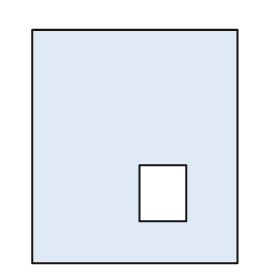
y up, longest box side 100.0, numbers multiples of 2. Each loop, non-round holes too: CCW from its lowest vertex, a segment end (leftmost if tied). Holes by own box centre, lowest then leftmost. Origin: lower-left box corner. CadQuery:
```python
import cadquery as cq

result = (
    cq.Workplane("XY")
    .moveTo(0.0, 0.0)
    .lineTo(88.0, 0.0)
    .lineTo(88.0, 100.0)
    .lineTo(0.0, 100.0)
    .close()
    .moveTo(46.0, 18.0)
    .lineTo(66.0, 18.0)
    .lineTo(66.0, 42.0)
    .lineTo(46.0, 42.0)
    .close()
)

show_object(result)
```